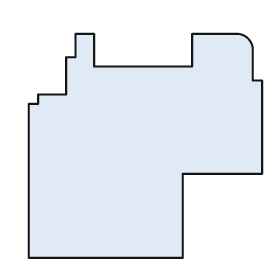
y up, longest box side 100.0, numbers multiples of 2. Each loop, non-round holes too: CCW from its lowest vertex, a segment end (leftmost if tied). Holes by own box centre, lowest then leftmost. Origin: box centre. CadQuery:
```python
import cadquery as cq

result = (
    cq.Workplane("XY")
    .moveTo(-50.0, -48.0)
    .lineTo(16.0, -48.0)
    .lineTo(16.0, -12.0)
    .lineTo(50.0, -12.0)
    .lineTo(50.0, 28.0)
    .lineTo(46.0, 28.0)
    .lineTo(46.0, 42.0)
    .threePointArc((44.0, 46.0), (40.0, 48.0))
    .lineTo(20.0, 48.0)
    .lineTo(20.0, 34.0)
    .lineTo(-22.0, 34.0)
    .lineTo(-22.0, 48.0)
    .lineTo(-30.0, 48.0)
    .lineTo(-30.0, 38.0)
    .lineTo(-34.0, 38.0)
    .lineTo(-34.0, 22.0)
    .lineTo(-46.0, 22.0)
    .lineTo(-46.0, 18.0)
    .lineTo(-50.0, 18.0)
    .close()
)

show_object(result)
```